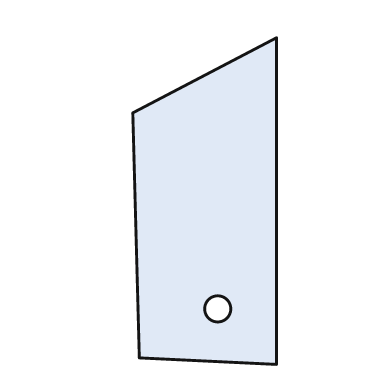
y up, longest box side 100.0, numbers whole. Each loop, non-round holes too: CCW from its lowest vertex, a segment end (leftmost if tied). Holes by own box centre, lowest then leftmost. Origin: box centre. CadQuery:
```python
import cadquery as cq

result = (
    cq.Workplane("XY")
    .moveTo(22.0, -50.0)
    .lineTo(22.0, 50.0)
    .lineTo(-22.0, 27.0)
    .lineTo(-20.0, -48.0)
    .close()
    .moveTo(4.0, -33.0)
    .circle(4.0)
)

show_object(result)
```